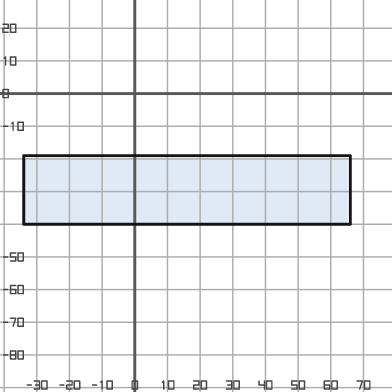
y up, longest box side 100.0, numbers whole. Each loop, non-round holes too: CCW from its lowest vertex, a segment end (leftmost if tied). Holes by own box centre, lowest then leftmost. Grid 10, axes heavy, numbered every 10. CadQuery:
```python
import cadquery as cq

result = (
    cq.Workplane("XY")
    .moveTo(-34.0, -40.0)
    .lineTo(66.0, -40.0)
    .lineTo(66.0, -19.0)
    .lineTo(-34.0, -19.0)
    .close()
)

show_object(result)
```